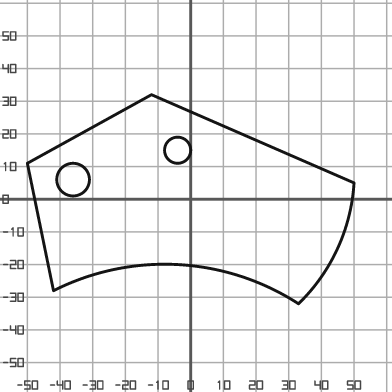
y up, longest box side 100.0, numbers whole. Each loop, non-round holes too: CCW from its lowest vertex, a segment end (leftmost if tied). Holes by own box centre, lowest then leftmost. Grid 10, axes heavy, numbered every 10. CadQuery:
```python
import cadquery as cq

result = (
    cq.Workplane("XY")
    .moveTo(33.0, -32.0)
    .threePointArc((45.0, -15.0), (50.0, 5.0))
    .lineTo(-12.0, 32.0)
    .lineTo(-50.0, 11.0)
    .lineTo(-42.0, -28.0)
    .threePointArc((-4.0, -20.0), (33.0, -32.0))
    .close()
    .moveTo(-36.0, 6.0)
    .circle(5.0)
    .moveTo(-4.0, 15.0)
    .circle(4.0)
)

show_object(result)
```